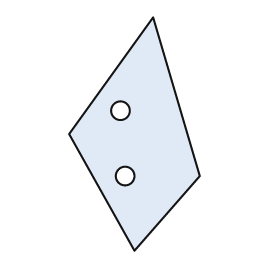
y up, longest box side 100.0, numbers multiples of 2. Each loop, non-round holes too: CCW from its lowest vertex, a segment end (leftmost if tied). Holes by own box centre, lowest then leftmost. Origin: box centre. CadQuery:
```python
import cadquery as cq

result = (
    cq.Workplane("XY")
    .moveTo(0.0, -50.0)
    .lineTo(28.0, -18.0)
    .lineTo(8.0, 50.0)
    .lineTo(-28.0, 0.0)
    .close()
    .moveTo(-4.0, -18.0)
    .circle(4.0)
    .moveTo(-6.0, 10.0)
    .circle(4.0)
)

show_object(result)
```